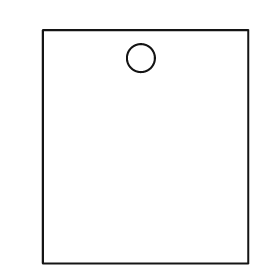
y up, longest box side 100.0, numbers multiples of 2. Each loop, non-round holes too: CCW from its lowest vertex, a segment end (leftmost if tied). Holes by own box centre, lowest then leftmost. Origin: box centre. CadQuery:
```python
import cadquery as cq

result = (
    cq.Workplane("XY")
    .moveTo(-44.0, -50.0)
    .lineTo(44.0, -50.0)
    .lineTo(44.0, 50.0)
    .lineTo(-44.0, 50.0)
    .close()
    .moveTo(-2.0, 38.0)
    .circle(6.0)
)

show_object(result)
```